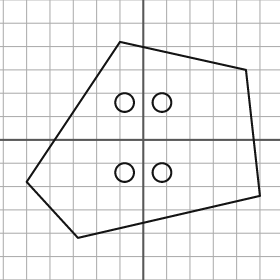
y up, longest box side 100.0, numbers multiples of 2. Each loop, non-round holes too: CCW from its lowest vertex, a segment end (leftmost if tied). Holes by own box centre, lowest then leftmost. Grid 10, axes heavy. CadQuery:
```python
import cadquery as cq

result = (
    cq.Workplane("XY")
    .moveTo(-28.0, -42.0)
    .lineTo(50.0, -24.0)
    .lineTo(44.0, 30.0)
    .lineTo(-10.0, 42.0)
    .lineTo(-50.0, -18.0)
    .close()
    .moveTo(-8.0, -14.0)
    .circle(4.0)
    .moveTo(8.0, -14.0)
    .circle(4.0)
    .moveTo(-8.0, 16.0)
    .circle(4.0)
    .moveTo(8.0, 16.0)
    .circle(4.0)
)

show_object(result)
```